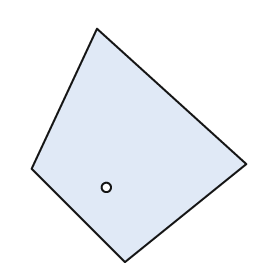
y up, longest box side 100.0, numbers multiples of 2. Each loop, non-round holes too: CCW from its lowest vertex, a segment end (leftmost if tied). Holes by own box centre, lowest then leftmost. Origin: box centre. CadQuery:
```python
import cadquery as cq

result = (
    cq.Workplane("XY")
    .moveTo(-6.0, -50.0)
    .lineTo(46.0, -8.0)
    .lineTo(-18.0, 50.0)
    .lineTo(-46.0, -10.0)
    .close()
    .moveTo(-14.0, -18.0)
    .circle(2.0)
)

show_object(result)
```